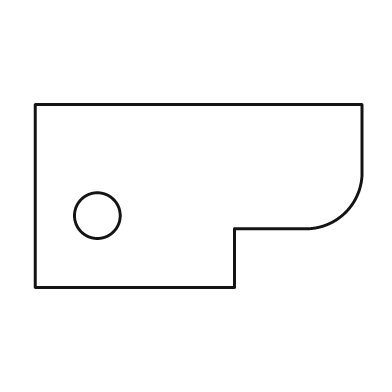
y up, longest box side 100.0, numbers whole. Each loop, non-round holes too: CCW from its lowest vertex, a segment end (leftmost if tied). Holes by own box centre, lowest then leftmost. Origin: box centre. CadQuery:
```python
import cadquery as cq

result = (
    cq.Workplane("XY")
    .moveTo(-50.0, -28.0)
    .lineTo(11.0, -28.0)
    .lineTo(11.0, -10.0)
    .lineTo(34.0, -10.0)
    .threePointArc((45.0, -5.0), (50.0, 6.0))
    .lineTo(50.0, 28.0)
    .lineTo(-50.0, 28.0)
    .close()
    .moveTo(-31.0, -6.0)
    .circle(7.0)
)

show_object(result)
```